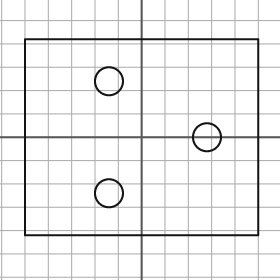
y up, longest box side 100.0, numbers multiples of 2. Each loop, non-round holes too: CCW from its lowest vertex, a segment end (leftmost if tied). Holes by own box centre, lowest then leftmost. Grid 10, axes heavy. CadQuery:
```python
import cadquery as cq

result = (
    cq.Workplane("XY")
    .moveTo(-50.0, -42.0)
    .lineTo(50.0, -42.0)
    .lineTo(50.0, 42.0)
    .lineTo(-50.0, 42.0)
    .close()
    .moveTo(-14.0, -24.0)
    .circle(6.0)
    .moveTo(28.0, 0.0)
    .circle(6.0)
    .moveTo(-14.0, 24.0)
    .circle(6.0)
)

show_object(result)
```